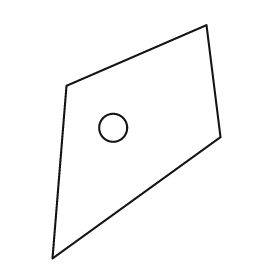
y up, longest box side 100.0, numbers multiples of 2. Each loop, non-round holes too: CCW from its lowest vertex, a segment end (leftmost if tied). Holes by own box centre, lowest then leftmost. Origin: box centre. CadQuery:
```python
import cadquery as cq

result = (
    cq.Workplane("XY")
    .moveTo(-36.0, -50.0)
    .lineTo(36.0, 2.0)
    .lineTo(30.0, 50.0)
    .lineTo(-30.0, 24.0)
    .close()
    .moveTo(-10.0, 6.0)
    .circle(6.0)
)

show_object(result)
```